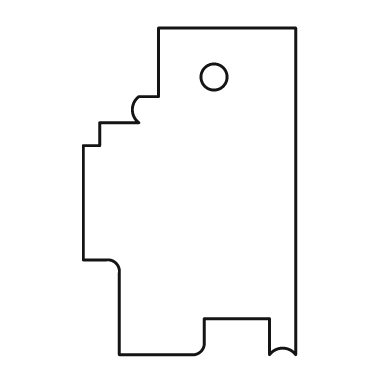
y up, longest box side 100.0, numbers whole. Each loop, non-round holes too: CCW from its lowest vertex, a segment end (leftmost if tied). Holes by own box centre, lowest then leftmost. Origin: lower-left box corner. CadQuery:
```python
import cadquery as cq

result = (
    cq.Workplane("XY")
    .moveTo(11.0, 0.0)
    .lineTo(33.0, 0.0)
    .threePointArc((36.0, 1.0), (37.0, 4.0))
    .lineTo(37.0, 11.0)
    .lineTo(57.0, 11.0)
    .lineTo(57.0, 0.0)
    .threePointArc((61.0, 2.0), (65.0, 0.0))
    .lineTo(65.0, 100.0)
    .lineTo(23.0, 100.0)
    .lineTo(23.0, 79.0)
    .lineTo(17.0, 79.0)
    .threePointArc((15.0, 75.0), (17.0, 71.0))
    .lineTo(5.0, 71.0)
    .lineTo(5.0, 64.0)
    .lineTo(0.0, 64.0)
    .lineTo(0.0, 29.0)
    .lineTo(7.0, 29.0)
    .threePointArc((10.0, 28.0), (11.0, 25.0))
    .close()
    .moveTo(40.0, 85.0)
    .circle(4.0)
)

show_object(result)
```